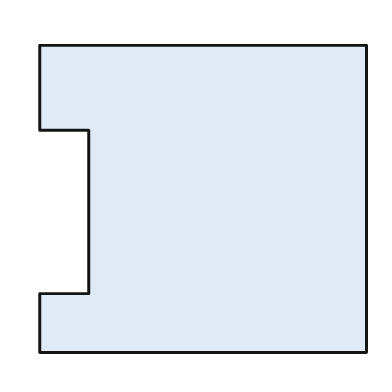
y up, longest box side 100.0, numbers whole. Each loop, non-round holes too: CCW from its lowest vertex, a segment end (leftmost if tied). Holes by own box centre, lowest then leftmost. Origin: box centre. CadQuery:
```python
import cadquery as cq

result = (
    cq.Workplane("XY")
    .moveTo(-50.0, -47.0)
    .lineTo(50.0, -47.0)
    .lineTo(50.0, 47.0)
    .lineTo(-50.0, 47.0)
    .lineTo(-50.0, 21.0)
    .lineTo(-35.0, 21.0)
    .lineTo(-35.0, -29.0)
    .lineTo(-50.0, -29.0)
    .close()
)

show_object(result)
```